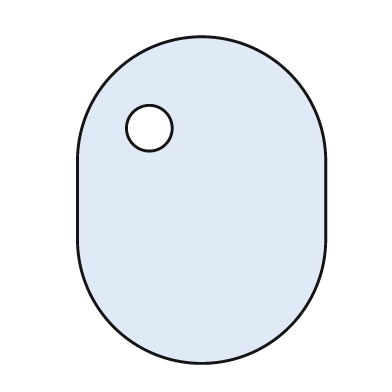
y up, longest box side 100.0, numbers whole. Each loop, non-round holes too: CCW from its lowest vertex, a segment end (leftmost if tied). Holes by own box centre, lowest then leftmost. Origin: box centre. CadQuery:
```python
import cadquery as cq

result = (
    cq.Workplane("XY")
    .moveTo(-38.0, -12.0)
    .threePointArc((0.0, -50.0), (38.0, -12.0))
    .lineTo(38.0, 12.0)
    .threePointArc((0.0, 50.0), (-38.0, 12.0))
    .close()
    .moveTo(-16.0, 22.0)
    .circle(7.0)
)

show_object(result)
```